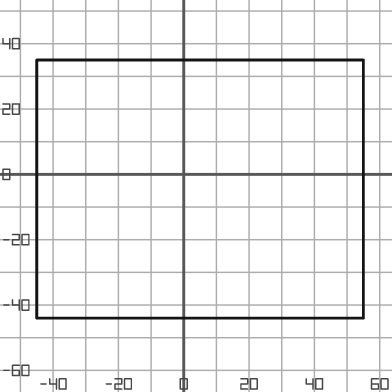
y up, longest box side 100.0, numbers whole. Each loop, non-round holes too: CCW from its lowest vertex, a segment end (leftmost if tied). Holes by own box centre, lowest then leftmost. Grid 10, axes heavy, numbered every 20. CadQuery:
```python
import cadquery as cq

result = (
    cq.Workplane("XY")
    .moveTo(-45.0, -44.0)
    .lineTo(55.0, -44.0)
    .lineTo(55.0, 35.0)
    .lineTo(-45.0, 35.0)
    .close()
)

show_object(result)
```